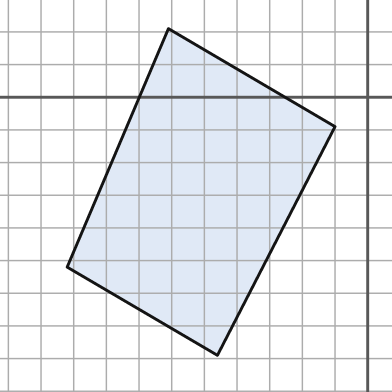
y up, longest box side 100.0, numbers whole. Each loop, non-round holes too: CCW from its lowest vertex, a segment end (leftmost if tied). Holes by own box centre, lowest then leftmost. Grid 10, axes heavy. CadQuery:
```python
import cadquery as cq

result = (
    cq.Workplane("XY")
    .moveTo(-46.0, -79.0)
    .lineTo(-10.0, -9.0)
    .lineTo(-61.0, 21.0)
    .lineTo(-92.0, -52.0)
    .close()
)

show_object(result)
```